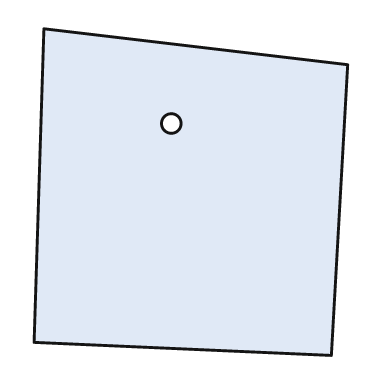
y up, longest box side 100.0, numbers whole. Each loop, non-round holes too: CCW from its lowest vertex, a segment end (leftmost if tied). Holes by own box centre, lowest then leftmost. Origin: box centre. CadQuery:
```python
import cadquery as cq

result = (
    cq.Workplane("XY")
    .moveTo(43.0, -50.0)
    .lineTo(48.0, 39.0)
    .lineTo(-45.0, 50.0)
    .lineTo(-48.0, -46.0)
    .close()
    .moveTo(-6.0, 21.0)
    .circle(3.0)
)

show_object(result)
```